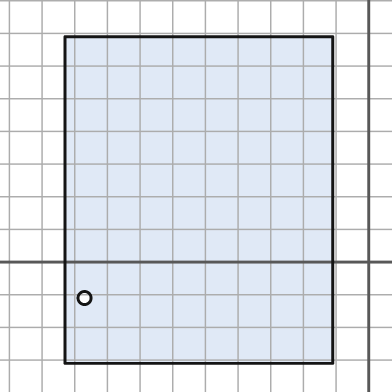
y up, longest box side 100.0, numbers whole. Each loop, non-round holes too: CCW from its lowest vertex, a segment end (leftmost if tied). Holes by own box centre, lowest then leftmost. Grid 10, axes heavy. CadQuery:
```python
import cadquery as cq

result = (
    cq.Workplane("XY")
    .moveTo(-93.0, -31.0)
    .lineTo(-11.0, -31.0)
    .lineTo(-11.0, 69.0)
    .lineTo(-93.0, 69.0)
    .close()
    .moveTo(-87.0, -11.0)
    .circle(2.0)
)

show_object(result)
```